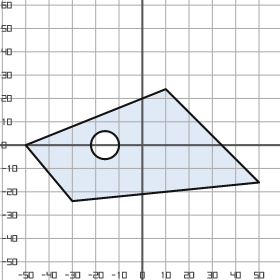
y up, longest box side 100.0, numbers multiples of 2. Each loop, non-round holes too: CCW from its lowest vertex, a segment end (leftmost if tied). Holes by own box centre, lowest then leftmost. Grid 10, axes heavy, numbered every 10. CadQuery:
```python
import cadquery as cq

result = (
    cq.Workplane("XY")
    .moveTo(-30.0, -24.0)
    .lineTo(50.0, -16.0)
    .lineTo(10.0, 24.0)
    .lineTo(-50.0, 0.0)
    .close()
    .moveTo(-16.0, 0.0)
    .circle(6.0)
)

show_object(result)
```